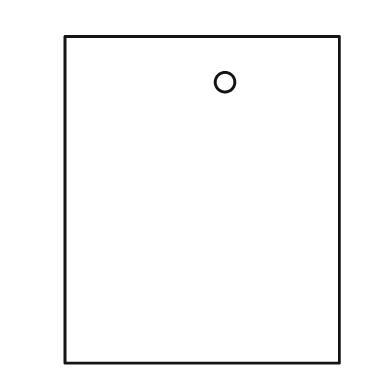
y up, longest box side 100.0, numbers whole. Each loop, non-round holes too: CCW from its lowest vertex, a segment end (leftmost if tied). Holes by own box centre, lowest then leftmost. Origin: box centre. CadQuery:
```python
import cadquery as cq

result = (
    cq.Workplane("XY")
    .moveTo(-42.0, -50.0)
    .lineTo(42.0, -50.0)
    .lineTo(42.0, 50.0)
    .lineTo(-42.0, 50.0)
    .close()
    .moveTo(7.0, 36.0)
    .circle(3.0)
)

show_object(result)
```